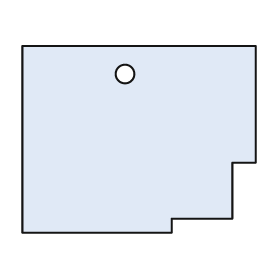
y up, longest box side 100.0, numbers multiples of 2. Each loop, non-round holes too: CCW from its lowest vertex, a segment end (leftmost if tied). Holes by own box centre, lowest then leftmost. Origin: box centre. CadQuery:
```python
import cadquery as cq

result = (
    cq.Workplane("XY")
    .moveTo(-50.0, -40.0)
    .lineTo(14.0, -40.0)
    .lineTo(14.0, -34.0)
    .lineTo(40.0, -34.0)
    .lineTo(40.0, -10.0)
    .lineTo(50.0, -10.0)
    .lineTo(50.0, 40.0)
    .lineTo(-50.0, 40.0)
    .close()
    .moveTo(-6.0, 28.0)
    .circle(4.0)
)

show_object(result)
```